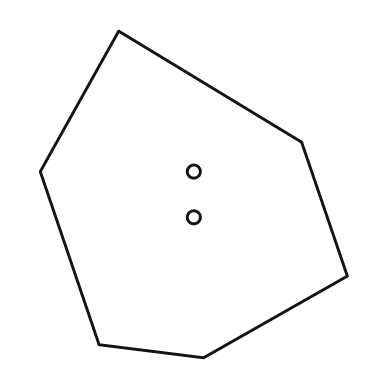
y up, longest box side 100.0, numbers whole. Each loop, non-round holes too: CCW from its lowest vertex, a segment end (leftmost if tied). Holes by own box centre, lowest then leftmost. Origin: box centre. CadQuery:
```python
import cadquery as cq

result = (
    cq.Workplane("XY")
    .moveTo(3.0, -50.0)
    .lineTo(47.0, -25.0)
    .lineTo(33.0, 16.0)
    .lineTo(-23.0, 50.0)
    .lineTo(-47.0, 7.0)
    .lineTo(-29.0, -46.0)
    .close()
    .moveTo(0.0, -7.0)
    .circle(2.0)
    .moveTo(0.0, 7.0)
    .circle(2.0)
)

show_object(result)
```